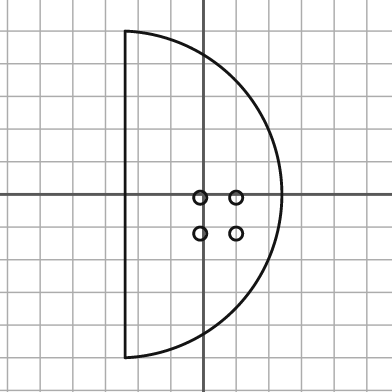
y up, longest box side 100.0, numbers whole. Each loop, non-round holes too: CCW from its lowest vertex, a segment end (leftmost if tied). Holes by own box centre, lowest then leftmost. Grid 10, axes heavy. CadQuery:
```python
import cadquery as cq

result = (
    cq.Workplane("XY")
    .moveTo(-24.0, -50.0)
    .threePointArc((24.0, 0.0), (-24.0, 50.0))
    .close()
    .moveTo(-1.0, -12.0)
    .circle(2.0)
    .moveTo(10.0, -12.0)
    .circle(2.0)
    .moveTo(-1.0, -1.0)
    .circle(2.0)
    .moveTo(10.0, -1.0)
    .circle(2.0)
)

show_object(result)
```